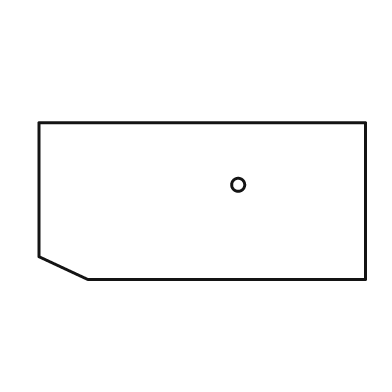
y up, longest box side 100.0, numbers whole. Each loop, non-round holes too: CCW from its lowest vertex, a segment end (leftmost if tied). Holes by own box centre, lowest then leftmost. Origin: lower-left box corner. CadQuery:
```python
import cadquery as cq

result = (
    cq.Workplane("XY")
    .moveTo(15.0, 0.0)
    .lineTo(100.0, 0.0)
    .lineTo(100.0, 48.0)
    .lineTo(0.0, 48.0)
    .lineTo(0.0, 7.0)
    .close()
    .moveTo(61.0, 29.0)
    .circle(2.0)
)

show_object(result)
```